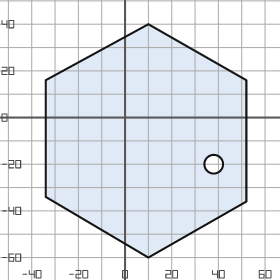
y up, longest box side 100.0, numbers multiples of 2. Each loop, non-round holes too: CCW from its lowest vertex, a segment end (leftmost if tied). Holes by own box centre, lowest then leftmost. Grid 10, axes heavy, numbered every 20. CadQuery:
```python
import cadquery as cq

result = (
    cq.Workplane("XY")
    .moveTo(10.0, -60.0)
    .lineTo(52.0, -36.0)
    .lineTo(52.0, 16.0)
    .lineTo(10.0, 40.0)
    .lineTo(-34.0, 16.0)
    .lineTo(-34.0, -34.0)
    .close()
    .moveTo(38.0, -20.0)
    .circle(4.0)
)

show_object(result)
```